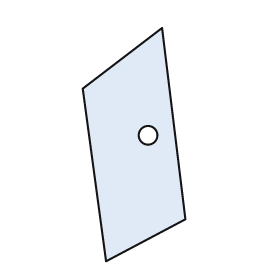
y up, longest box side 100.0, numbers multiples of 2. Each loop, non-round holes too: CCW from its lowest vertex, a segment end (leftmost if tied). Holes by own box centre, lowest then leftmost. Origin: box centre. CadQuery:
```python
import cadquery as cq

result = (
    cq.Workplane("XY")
    .moveTo(-12.0, -50.0)
    .lineTo(22.0, -32.0)
    .lineTo(12.0, 50.0)
    .lineTo(-22.0, 24.0)
    .close()
    .moveTo(6.0, 4.0)
    .circle(4.0)
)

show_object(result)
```